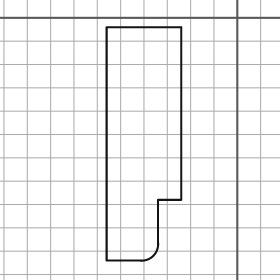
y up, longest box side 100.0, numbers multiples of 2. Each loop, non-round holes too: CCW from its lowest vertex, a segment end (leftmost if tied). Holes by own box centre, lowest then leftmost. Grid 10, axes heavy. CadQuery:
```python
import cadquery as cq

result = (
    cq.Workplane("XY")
    .moveTo(-56.0, -104.0)
    .lineTo(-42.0, -104.0)
    .threePointArc((-36.0, -102.0), (-34.0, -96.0))
    .lineTo(-34.0, -78.0)
    .lineTo(-24.0, -78.0)
    .lineTo(-24.0, -4.0)
    .lineTo(-56.0, -4.0)
    .close()
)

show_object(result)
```